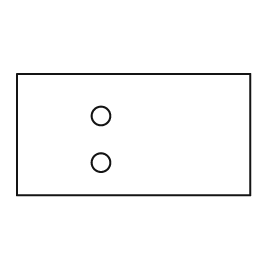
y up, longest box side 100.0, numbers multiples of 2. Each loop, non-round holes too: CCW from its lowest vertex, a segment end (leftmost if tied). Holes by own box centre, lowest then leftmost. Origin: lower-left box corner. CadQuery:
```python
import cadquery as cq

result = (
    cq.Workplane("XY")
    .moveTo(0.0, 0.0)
    .lineTo(100.0, 0.0)
    .lineTo(100.0, 52.0)
    .lineTo(0.0, 52.0)
    .close()
    .moveTo(36.0, 14.0)
    .circle(4.0)
    .moveTo(36.0, 34.0)
    .circle(4.0)
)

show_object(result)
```